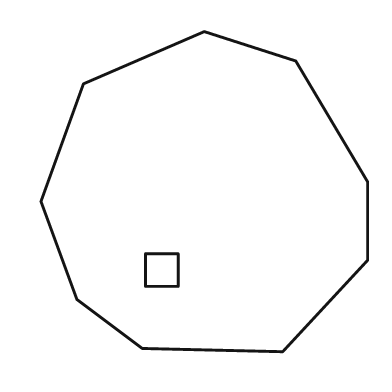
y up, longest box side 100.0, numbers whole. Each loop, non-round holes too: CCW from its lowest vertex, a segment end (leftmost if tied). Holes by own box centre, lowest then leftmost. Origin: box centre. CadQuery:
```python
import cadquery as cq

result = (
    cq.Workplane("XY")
    .moveTo(24.0, -49.0)
    .lineTo(50.0, -21.0)
    .lineTo(50.0, 3.0)
    .lineTo(28.0, 40.0)
    .lineTo(0.0, 49.0)
    .lineTo(-37.0, 33.0)
    .lineTo(-50.0, -3.0)
    .lineTo(-39.0, -33.0)
    .lineTo(-19.0, -48.0)
    .close()
    .moveTo(-18.0, -29.0)
    .lineTo(-8.0, -29.0)
    .lineTo(-8.0, -19.0)
    .lineTo(-18.0, -19.0)
    .close()
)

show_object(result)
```